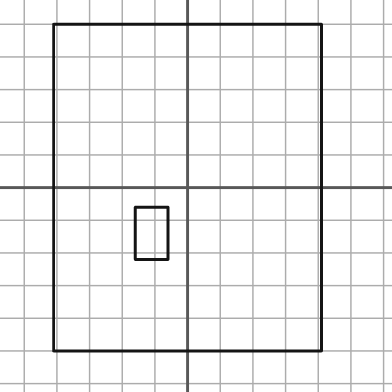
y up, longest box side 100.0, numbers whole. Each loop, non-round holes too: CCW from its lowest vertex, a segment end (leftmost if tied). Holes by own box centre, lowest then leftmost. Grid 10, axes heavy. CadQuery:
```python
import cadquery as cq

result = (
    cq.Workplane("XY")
    .moveTo(-41.0, -50.0)
    .lineTo(41.0, -50.0)
    .lineTo(41.0, 50.0)
    .lineTo(-41.0, 50.0)
    .close()
    .moveTo(-16.0, -22.0)
    .lineTo(-6.0, -22.0)
    .lineTo(-6.0, -6.0)
    .lineTo(-16.0, -6.0)
    .close()
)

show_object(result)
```